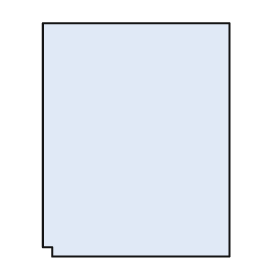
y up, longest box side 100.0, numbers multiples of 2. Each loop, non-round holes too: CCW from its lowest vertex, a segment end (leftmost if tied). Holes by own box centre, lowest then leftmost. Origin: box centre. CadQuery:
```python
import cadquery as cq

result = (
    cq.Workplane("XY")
    .moveTo(-36.0, -50.0)
    .lineTo(40.0, -50.0)
    .lineTo(40.0, 50.0)
    .lineTo(-40.0, 50.0)
    .lineTo(-40.0, -46.0)
    .lineTo(-36.0, -46.0)
    .close()
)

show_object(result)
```